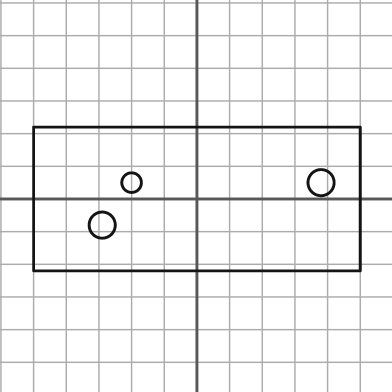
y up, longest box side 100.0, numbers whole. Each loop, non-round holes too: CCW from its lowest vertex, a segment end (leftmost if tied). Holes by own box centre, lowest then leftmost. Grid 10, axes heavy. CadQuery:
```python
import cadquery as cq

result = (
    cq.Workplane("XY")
    .moveTo(-50.0, -22.0)
    .lineTo(50.0, -22.0)
    .lineTo(50.0, 22.0)
    .lineTo(-50.0, 22.0)
    .close()
    .moveTo(-29.0, -8.0)
    .circle(4.0)
    .moveTo(-20.0, 5.0)
    .circle(3.0)
    .moveTo(38.0, 5.0)
    .circle(4.0)
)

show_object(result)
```